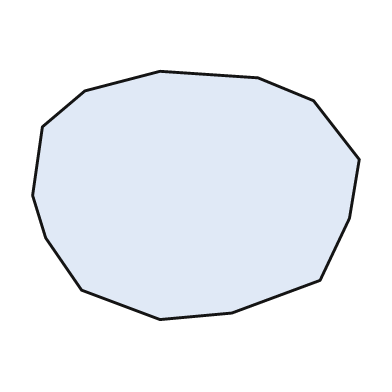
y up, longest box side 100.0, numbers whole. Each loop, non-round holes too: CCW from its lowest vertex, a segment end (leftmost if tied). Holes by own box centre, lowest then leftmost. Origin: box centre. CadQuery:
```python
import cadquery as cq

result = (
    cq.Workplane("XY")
    .moveTo(-11.0, -38.0)
    .lineTo(11.0, -36.0)
    .lineTo(38.0, -26.0)
    .lineTo(47.0, -7.0)
    .lineTo(50.0, 11.0)
    .lineTo(36.0, 29.0)
    .lineTo(19.0, 36.0)
    .lineTo(-11.0, 38.0)
    .lineTo(-34.0, 32.0)
    .lineTo(-47.0, 21.0)
    .lineTo(-50.0, 0.0)
    .lineTo(-46.0, -13.0)
    .lineTo(-35.0, -29.0)
    .close()
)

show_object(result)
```